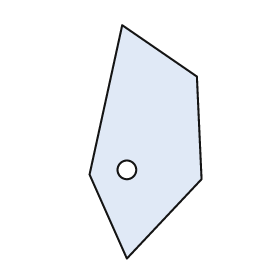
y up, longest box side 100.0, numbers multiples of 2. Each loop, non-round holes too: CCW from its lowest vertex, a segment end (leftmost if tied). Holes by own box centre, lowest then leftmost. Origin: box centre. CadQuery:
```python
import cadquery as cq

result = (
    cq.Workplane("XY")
    .moveTo(-8.0, -50.0)
    .lineTo(24.0, -16.0)
    .lineTo(22.0, 28.0)
    .lineTo(-10.0, 50.0)
    .lineTo(-24.0, -14.0)
    .close()
    .moveTo(-8.0, -12.0)
    .circle(4.0)
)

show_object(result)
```